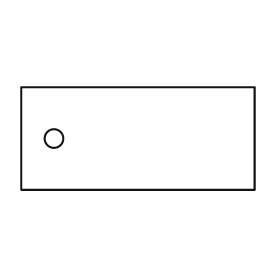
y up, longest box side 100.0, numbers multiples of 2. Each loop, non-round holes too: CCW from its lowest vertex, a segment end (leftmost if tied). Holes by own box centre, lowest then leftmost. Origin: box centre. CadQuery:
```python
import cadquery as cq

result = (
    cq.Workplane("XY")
    .moveTo(-50.0, -22.0)
    .lineTo(50.0, -22.0)
    .lineTo(50.0, 22.0)
    .lineTo(-50.0, 22.0)
    .close()
    .moveTo(-36.0, 0.0)
    .circle(4.0)
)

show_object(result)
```